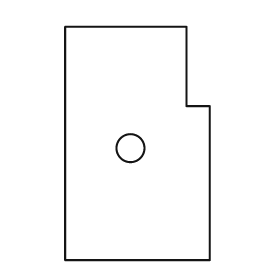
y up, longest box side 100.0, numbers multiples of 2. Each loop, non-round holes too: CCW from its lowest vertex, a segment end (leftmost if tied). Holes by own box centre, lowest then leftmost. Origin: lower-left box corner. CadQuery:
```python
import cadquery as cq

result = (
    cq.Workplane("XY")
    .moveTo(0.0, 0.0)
    .lineTo(62.0, 0.0)
    .lineTo(62.0, 66.0)
    .lineTo(52.0, 66.0)
    .lineTo(52.0, 100.0)
    .lineTo(0.0, 100.0)
    .close()
    .moveTo(28.0, 48.0)
    .circle(6.0)
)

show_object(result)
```